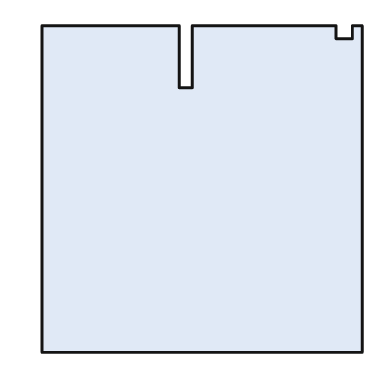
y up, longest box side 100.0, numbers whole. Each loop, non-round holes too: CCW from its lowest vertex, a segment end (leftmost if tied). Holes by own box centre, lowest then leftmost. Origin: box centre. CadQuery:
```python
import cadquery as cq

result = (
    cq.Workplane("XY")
    .moveTo(-49.0, -50.0)
    .lineTo(49.0, -50.0)
    .lineTo(49.0, 50.0)
    .lineTo(46.0, 50.0)
    .lineTo(46.0, 46.0)
    .lineTo(41.0, 46.0)
    .lineTo(41.0, 50.0)
    .lineTo(-3.0, 50.0)
    .lineTo(-3.0, 31.0)
    .lineTo(-7.0, 31.0)
    .lineTo(-7.0, 50.0)
    .lineTo(-49.0, 50.0)
    .close()
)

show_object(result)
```